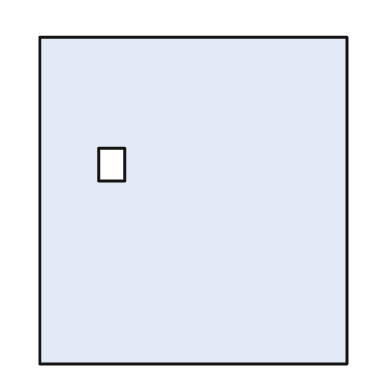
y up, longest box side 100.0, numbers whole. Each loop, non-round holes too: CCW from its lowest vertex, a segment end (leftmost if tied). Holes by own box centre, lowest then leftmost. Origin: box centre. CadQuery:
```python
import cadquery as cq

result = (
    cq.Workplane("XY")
    .moveTo(-47.0, -50.0)
    .lineTo(47.0, -50.0)
    .lineTo(47.0, 50.0)
    .lineTo(-47.0, 50.0)
    .close()
    .moveTo(-29.0, 6.0)
    .lineTo(-21.0, 6.0)
    .lineTo(-21.0, 16.0)
    .lineTo(-29.0, 16.0)
    .close()
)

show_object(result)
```